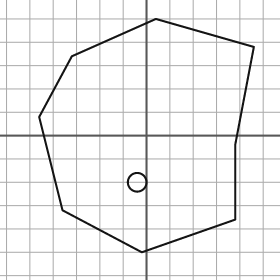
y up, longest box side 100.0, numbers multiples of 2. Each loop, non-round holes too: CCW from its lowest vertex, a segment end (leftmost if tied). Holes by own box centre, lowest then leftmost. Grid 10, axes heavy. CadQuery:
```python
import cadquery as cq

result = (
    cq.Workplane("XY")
    .moveTo(-2.0, -50.0)
    .lineTo(38.0, -36.0)
    .lineTo(38.0, -4.0)
    .lineTo(46.0, 38.0)
    .lineTo(4.0, 50.0)
    .lineTo(-32.0, 34.0)
    .lineTo(-46.0, 8.0)
    .lineTo(-36.0, -32.0)
    .close()
    .moveTo(-4.0, -20.0)
    .circle(4.0)
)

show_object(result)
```